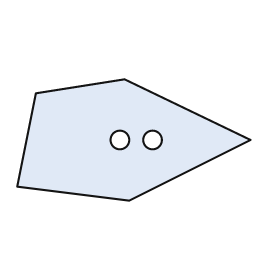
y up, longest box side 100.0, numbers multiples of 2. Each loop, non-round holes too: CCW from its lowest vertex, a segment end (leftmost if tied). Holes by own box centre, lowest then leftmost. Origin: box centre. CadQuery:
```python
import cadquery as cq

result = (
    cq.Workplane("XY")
    .moveTo(-2.0, -26.0)
    .lineTo(50.0, 0.0)
    .lineTo(-4.0, 26.0)
    .lineTo(-42.0, 20.0)
    .lineTo(-50.0, -20.0)
    .close()
    .moveTo(-6.0, 0.0)
    .circle(4.0)
    .moveTo(8.0, 0.0)
    .circle(4.0)
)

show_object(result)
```